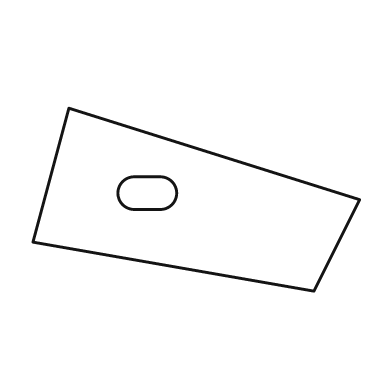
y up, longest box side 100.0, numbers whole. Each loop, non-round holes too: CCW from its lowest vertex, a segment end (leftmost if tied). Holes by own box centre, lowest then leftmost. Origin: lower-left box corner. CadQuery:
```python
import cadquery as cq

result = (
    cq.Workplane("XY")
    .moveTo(86.0, 0.0)
    .lineTo(100.0, 28.0)
    .lineTo(11.0, 56.0)
    .lineTo(0.0, 15.0)
    .close()
    .moveTo(31.0, 25.0)
    .lineTo(39.0, 25.0)
    .threePointArc((44.0, 30.0), (39.0, 35.0))
    .lineTo(31.0, 35.0)
    .threePointArc((26.0, 30.0), (31.0, 25.0))
    .close()
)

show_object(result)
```